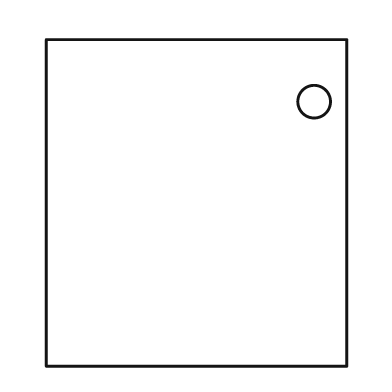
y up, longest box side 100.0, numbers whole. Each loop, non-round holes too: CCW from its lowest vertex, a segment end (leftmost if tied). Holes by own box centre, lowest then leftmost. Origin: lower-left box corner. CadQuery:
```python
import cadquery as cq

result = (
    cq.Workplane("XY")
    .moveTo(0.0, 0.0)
    .lineTo(92.0, 0.0)
    .lineTo(92.0, 100.0)
    .lineTo(0.0, 100.0)
    .close()
    .moveTo(82.0, 81.0)
    .circle(5.0)
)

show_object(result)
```